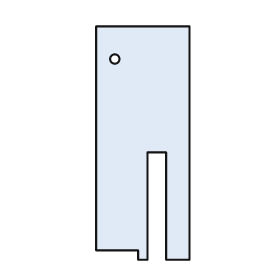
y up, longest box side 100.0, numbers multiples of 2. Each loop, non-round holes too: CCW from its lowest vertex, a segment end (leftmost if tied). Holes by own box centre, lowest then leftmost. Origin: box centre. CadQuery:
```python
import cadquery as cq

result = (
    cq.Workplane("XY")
    .moveTo(-2.0, -50.0)
    .lineTo(2.0, -50.0)
    .lineTo(2.0, -4.0)
    .lineTo(10.0, -4.0)
    .lineTo(10.0, -50.0)
    .lineTo(20.0, -50.0)
    .lineTo(20.0, 50.0)
    .lineTo(-20.0, 50.0)
    .lineTo(-20.0, -46.0)
    .lineTo(-2.0, -46.0)
    .close()
    .moveTo(-12.0, 36.0)
    .circle(2.0)
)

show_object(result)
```